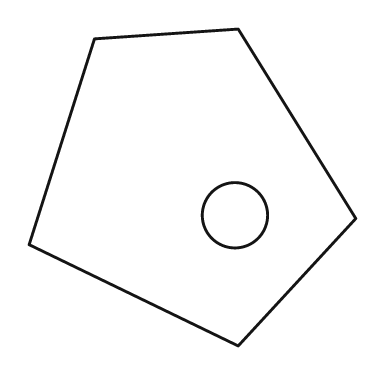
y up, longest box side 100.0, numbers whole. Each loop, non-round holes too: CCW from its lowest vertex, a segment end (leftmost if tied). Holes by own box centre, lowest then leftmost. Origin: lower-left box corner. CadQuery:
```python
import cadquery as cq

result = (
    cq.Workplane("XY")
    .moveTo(64.0, 0.0)
    .lineTo(100.0, 39.0)
    .lineTo(64.0, 97.0)
    .lineTo(20.0, 94.0)
    .lineTo(0.0, 31.0)
    .close()
    .moveTo(63.0, 40.0)
    .circle(10.0)
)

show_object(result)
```